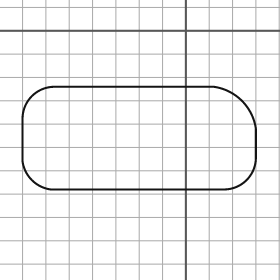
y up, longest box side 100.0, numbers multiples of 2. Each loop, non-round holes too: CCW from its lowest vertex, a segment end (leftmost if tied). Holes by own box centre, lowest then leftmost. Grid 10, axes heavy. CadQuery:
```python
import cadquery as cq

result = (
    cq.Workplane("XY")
    .moveTo(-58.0, -68.0)
    .lineTo(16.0, -68.0)
    .threePointArc((26.0, -64.0), (30.0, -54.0))
    .lineTo(30.0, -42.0)
    .threePointArc((24.0, -30.0), (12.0, -24.0))
    .lineTo(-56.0, -24.0)
    .threePointArc((-66.0, -28.0), (-70.0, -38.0))
    .lineTo(-70.0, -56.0)
    .threePointArc((-66.0, -64.0), (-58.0, -68.0))
    .close()
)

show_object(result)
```